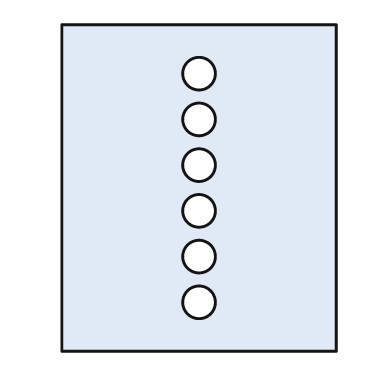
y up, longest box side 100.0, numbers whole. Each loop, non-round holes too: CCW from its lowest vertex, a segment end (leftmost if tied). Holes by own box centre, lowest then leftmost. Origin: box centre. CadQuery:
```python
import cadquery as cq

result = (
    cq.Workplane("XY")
    .moveTo(-42.0, -50.0)
    .lineTo(42.0, -50.0)
    .lineTo(42.0, 50.0)
    .lineTo(-42.0, 50.0)
    .close()
    .moveTo(0.0, -35.0)
    .circle(5.0)
    .moveTo(0.0, -21.0)
    .circle(5.0)
    .moveTo(0.0, -7.0)
    .circle(5.0)
    .moveTo(0.0, 7.0)
    .circle(5.0)
    .moveTo(0.0, 21.0)
    .circle(5.0)
    .moveTo(0.0, 35.0)
    .circle(5.0)
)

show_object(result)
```